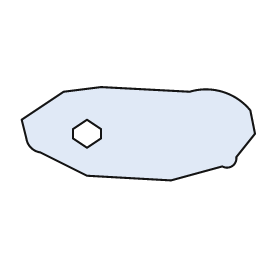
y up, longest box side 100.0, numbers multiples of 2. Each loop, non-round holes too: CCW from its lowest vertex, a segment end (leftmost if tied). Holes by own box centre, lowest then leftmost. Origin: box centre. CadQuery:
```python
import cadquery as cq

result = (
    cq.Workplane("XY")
    .moveTo(14.0, -20.0)
    .lineTo(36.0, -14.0)
    .threePointArc((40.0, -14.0), (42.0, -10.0))
    .lineTo(50.0, 0.0)
    .lineTo(48.0, 10.0)
    .threePointArc((36.0, 18.0), (22.0, 18.0))
    .lineTo(-16.0, 20.0)
    .lineTo(-32.0, 18.0)
    .lineTo(-50.0, 6.0)
    .lineTo(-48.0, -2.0)
    .threePointArc((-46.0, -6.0), (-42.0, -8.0))
    .lineTo(-22.0, -18.0)
    .close()
    .moveTo(-22.0, -6.0)
    .lineTo(-16.0, -2.0)
    .lineTo(-16.0, 2.0)
    .lineTo(-22.0, 6.0)
    .lineTo(-28.0, 2.0)
    .lineTo(-28.0, -2.0)
    .close()
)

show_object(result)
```